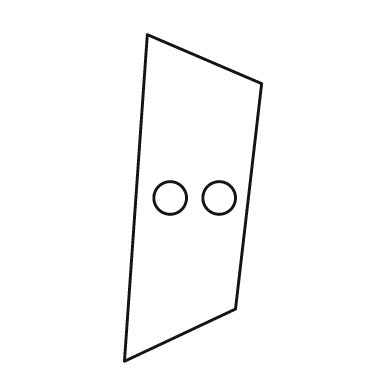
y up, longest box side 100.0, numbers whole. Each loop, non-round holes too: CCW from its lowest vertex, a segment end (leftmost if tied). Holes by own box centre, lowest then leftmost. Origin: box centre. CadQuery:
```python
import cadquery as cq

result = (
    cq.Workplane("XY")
    .moveTo(-21.0, -50.0)
    .lineTo(13.0, -34.0)
    .lineTo(21.0, 35.0)
    .lineTo(-14.0, 50.0)
    .close()
    .moveTo(-7.0, 0.0)
    .circle(5.0)
    .moveTo(8.0, 0.0)
    .circle(5.0)
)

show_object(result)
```